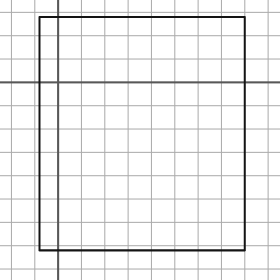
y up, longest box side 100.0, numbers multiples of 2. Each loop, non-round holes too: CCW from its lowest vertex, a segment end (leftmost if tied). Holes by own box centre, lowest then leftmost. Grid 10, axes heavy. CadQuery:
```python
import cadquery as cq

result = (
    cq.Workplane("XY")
    .moveTo(-8.0, -72.0)
    .lineTo(80.0, -72.0)
    .lineTo(80.0, 28.0)
    .lineTo(-8.0, 28.0)
    .close()
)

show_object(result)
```